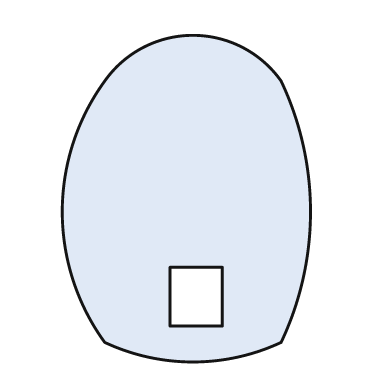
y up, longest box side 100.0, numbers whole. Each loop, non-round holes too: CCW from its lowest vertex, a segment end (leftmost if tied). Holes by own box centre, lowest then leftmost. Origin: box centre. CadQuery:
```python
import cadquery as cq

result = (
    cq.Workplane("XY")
    .moveTo(-25.0, -44.0)
    .threePointArc((2.0, -50.0), (29.0, -44.0))
    .threePointArc((38.0, -4.0), (29.0, 36.0))
    .threePointArc((2.0, 50.0), (-25.0, 36.0))
    .threePointArc((-38.0, -4.0), (-25.0, -44.0))
    .close()
    .moveTo(-5.0, -39.0)
    .lineTo(11.0, -39.0)
    .lineTo(11.0, -21.0)
    .lineTo(-5.0, -21.0)
    .close()
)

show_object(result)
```